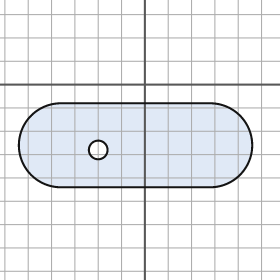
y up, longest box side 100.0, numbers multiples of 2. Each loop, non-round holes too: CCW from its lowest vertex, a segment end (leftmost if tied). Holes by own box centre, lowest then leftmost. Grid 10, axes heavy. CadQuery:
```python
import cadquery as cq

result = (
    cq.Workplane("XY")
    .moveTo(-36.0, -44.0)
    .lineTo(28.0, -44.0)
    .threePointArc((46.0, -26.0), (28.0, -8.0))
    .lineTo(-36.0, -8.0)
    .threePointArc((-54.0, -26.0), (-36.0, -44.0))
    .close()
    .moveTo(-20.0, -28.0)
    .circle(4.0)
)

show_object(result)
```